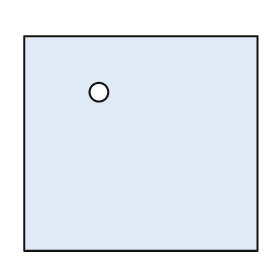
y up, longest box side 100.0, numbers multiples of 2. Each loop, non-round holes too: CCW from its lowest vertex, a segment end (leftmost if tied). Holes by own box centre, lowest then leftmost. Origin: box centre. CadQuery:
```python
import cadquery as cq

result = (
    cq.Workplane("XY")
    .moveTo(-50.0, -46.0)
    .lineTo(50.0, -46.0)
    .lineTo(50.0, 46.0)
    .lineTo(-50.0, 46.0)
    .close()
    .moveTo(-18.0, 22.0)
    .circle(4.0)
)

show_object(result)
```